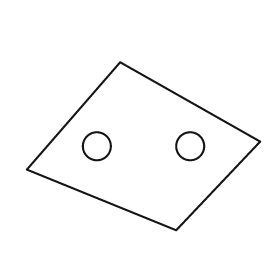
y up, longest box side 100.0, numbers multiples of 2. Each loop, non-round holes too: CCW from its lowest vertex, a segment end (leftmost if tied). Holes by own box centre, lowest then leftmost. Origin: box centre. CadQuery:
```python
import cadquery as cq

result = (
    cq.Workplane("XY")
    .moveTo(14.0, -36.0)
    .lineTo(50.0, 2.0)
    .lineTo(-10.0, 36.0)
    .lineTo(-50.0, -10.0)
    .close()
    .moveTo(-20.0, 0.0)
    .circle(6.0)
    .moveTo(20.0, 0.0)
    .circle(6.0)
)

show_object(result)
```